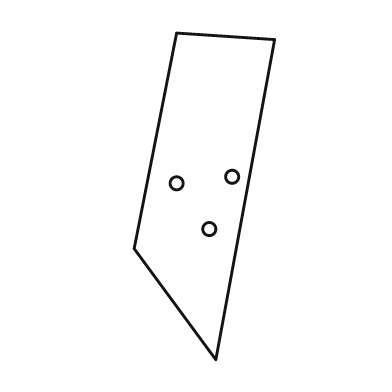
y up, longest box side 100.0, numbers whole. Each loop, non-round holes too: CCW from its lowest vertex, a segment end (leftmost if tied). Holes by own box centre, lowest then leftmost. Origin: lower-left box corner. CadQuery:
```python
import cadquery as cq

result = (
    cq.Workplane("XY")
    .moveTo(25.0, 0.0)
    .lineTo(43.0, 98.0)
    .lineTo(13.0, 100.0)
    .lineTo(0.0, 34.0)
    .close()
    .moveTo(23.0, 40.0)
    .circle(2.0)
    .moveTo(13.0, 54.0)
    .circle(2.0)
    .moveTo(30.0, 56.0)
    .circle(2.0)
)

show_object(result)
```